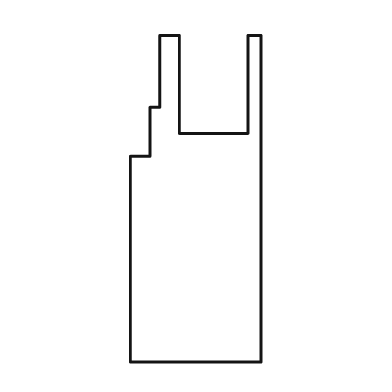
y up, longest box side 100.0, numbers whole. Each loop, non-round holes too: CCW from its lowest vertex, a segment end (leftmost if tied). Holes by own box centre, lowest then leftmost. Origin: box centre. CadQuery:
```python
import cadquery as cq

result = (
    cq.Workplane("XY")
    .moveTo(-20.0, -50.0)
    .lineTo(20.0, -50.0)
    .lineTo(20.0, 50.0)
    .lineTo(16.0, 50.0)
    .lineTo(16.0, 20.0)
    .lineTo(-5.0, 20.0)
    .lineTo(-5.0, 50.0)
    .lineTo(-11.0, 50.0)
    .lineTo(-11.0, 28.0)
    .lineTo(-14.0, 28.0)
    .lineTo(-14.0, 13.0)
    .lineTo(-20.0, 13.0)
    .close()
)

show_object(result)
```